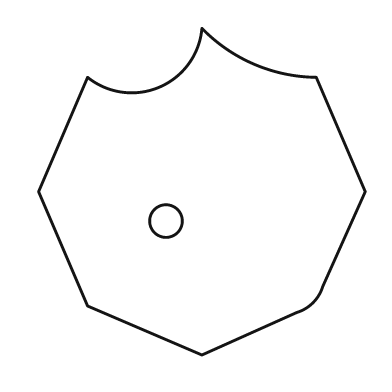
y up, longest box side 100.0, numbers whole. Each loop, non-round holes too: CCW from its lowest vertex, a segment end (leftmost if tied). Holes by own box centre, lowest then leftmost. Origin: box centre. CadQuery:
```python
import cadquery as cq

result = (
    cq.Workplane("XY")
    .moveTo(0.0, -50.0)
    .lineTo(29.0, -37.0)
    .threePointArc((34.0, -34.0), (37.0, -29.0))
    .lineTo(50.0, 0.0)
    .lineTo(35.0, 35.0)
    .threePointArc((16.0, 39.0), (0.0, 50.0))
    .threePointArc((-13.0, 32.0), (-35.0, 35.0))
    .lineTo(-50.0, 0.0)
    .lineTo(-35.0, -35.0)
    .close()
    .moveTo(-11.0, -9.0)
    .circle(5.0)
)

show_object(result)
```